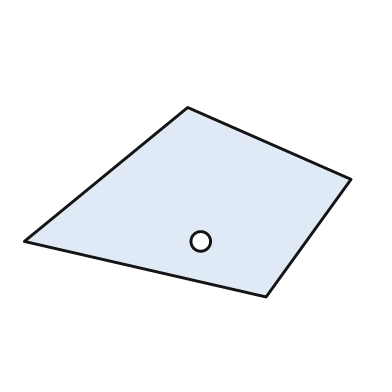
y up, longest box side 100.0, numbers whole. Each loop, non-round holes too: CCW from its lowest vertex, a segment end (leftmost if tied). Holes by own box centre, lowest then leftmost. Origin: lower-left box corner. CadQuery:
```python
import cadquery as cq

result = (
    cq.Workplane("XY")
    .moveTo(74.0, 0.0)
    .lineTo(100.0, 36.0)
    .lineTo(50.0, 58.0)
    .lineTo(0.0, 17.0)
    .close()
    .moveTo(54.0, 17.0)
    .circle(3.0)
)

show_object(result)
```